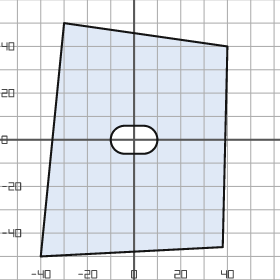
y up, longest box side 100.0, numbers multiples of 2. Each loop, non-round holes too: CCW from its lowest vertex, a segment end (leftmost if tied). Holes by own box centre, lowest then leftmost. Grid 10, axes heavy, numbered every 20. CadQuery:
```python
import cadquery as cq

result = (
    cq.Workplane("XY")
    .moveTo(-40.0, -50.0)
    .lineTo(38.0, -46.0)
    .lineTo(40.0, 40.0)
    .lineTo(-30.0, 50.0)
    .close()
    .moveTo(-4.0, -6.0)
    .lineTo(4.0, -6.0)
    .threePointArc((10.0, 0.0), (4.0, 6.0))
    .lineTo(-4.0, 6.0)
    .threePointArc((-10.0, 0.0), (-4.0, -6.0))
    .close()
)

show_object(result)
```